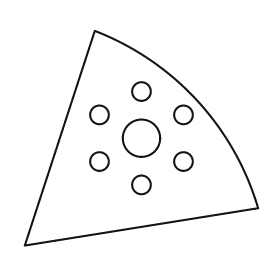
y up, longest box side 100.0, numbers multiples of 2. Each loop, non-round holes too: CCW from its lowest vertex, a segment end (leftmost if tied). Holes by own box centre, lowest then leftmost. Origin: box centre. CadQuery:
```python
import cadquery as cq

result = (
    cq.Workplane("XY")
    .moveTo(-50.0, -46.0)
    .lineTo(50.0, -30.0)
    .threePointArc((24.0, 16.0), (-20.0, 46.0))
    .close()
    .moveTo(0.0, -20.0)
    .circle(4.0)
    .moveTo(-18.0, -10.0)
    .circle(4.0)
    .moveTo(18.0, -10.0)
    .circle(4.0)
    .moveTo(0.0, 0.0)
    .circle(8.0)
    .moveTo(-18.0, 10.0)
    .circle(4.0)
    .moveTo(18.0, 10.0)
    .circle(4.0)
    .moveTo(0.0, 20.0)
    .circle(4.0)
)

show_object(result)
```